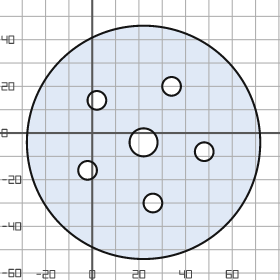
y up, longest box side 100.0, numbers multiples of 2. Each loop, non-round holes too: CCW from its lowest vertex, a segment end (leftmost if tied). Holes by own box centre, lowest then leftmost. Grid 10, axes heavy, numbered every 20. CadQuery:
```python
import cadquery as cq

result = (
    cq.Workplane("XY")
    .moveTo(22.0, -4.0)
    .circle(50.0)
    .moveTo(26.0, -30.0)
    .circle(4.0)
    .moveTo(-2.0, -16.0)
    .circle(4.0)
    .moveTo(48.0, -8.0)
    .circle(4.0)
    .moveTo(22.0, -4.0)
    .circle(6.0)
    .moveTo(2.0, 14.0)
    .circle(4.0)
    .moveTo(34.0, 20.0)
    .circle(4.0)
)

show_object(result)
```